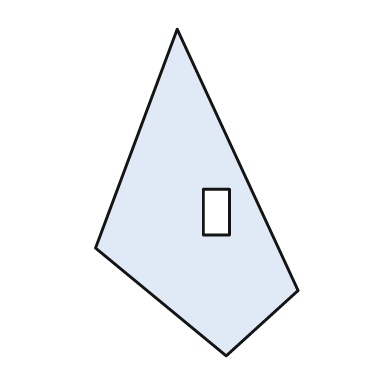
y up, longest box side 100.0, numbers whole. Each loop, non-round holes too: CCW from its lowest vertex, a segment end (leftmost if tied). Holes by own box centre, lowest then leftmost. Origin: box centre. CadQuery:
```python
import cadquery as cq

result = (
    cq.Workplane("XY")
    .moveTo(9.0, -50.0)
    .lineTo(31.0, -30.0)
    .lineTo(-6.0, 50.0)
    .lineTo(-31.0, -17.0)
    .close()
    .moveTo(2.0, -13.0)
    .lineTo(10.0, -13.0)
    .lineTo(10.0, 1.0)
    .lineTo(2.0, 1.0)
    .close()
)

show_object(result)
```